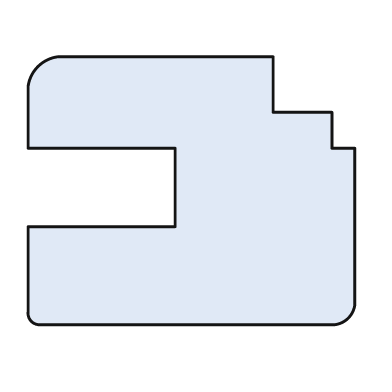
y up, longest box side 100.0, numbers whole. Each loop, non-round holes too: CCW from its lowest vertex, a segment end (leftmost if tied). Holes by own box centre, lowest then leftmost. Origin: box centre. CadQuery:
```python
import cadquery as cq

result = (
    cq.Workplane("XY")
    .moveTo(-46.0, -41.0)
    .lineTo(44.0, -41.0)
    .threePointArc((48.0, -39.0), (50.0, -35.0))
    .lineTo(50.0, 13.0)
    .lineTo(43.0, 13.0)
    .lineTo(43.0, 24.0)
    .lineTo(25.0, 24.0)
    .lineTo(25.0, 41.0)
    .lineTo(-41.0, 41.0)
    .threePointArc((-47.0, 38.0), (-50.0, 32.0))
    .lineTo(-50.0, 13.0)
    .lineTo(-5.0, 13.0)
    .lineTo(-5.0, -11.0)
    .lineTo(-50.0, -11.0)
    .lineTo(-50.0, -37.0)
    .threePointArc((-49.0, -40.0), (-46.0, -41.0))
    .close()
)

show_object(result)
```